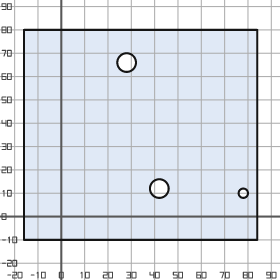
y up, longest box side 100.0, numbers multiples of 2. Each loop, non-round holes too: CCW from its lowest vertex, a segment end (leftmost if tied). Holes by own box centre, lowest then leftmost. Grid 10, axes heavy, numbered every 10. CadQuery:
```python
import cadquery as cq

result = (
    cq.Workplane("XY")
    .moveTo(-16.0, -10.0)
    .lineTo(84.0, -10.0)
    .lineTo(84.0, 80.0)
    .lineTo(-16.0, 80.0)
    .close()
    .moveTo(78.0, 10.0)
    .circle(2.0)
    .moveTo(42.0, 12.0)
    .circle(4.0)
    .moveTo(28.0, 66.0)
    .circle(4.0)
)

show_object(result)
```